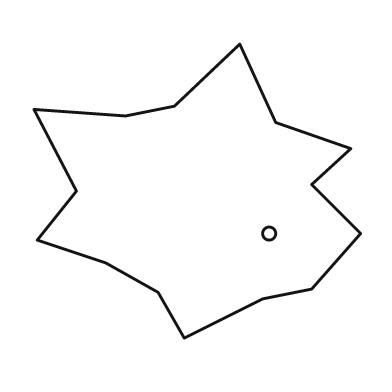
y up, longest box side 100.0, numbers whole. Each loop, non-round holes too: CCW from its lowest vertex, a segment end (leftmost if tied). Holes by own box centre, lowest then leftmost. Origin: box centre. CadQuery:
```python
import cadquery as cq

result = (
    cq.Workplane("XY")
    .moveTo(-4.0, -45.0)
    .lineTo(20.0, -33.0)
    .lineTo(35.0, -30.0)
    .lineTo(50.0, -13.0)
    .lineTo(35.0, 2.0)
    .lineTo(47.0, 13.0)
    .lineTo(24.0, 21.0)
    .lineTo(13.0, 45.0)
    .lineTo(-7.0, 26.0)
    .lineTo(-22.0, 23.0)
    .lineTo(-50.0, 25.0)
    .lineTo(-37.0, 0.0)
    .lineTo(-49.0, -15.0)
    .lineTo(-28.0, -22.0)
    .lineTo(-12.0, -31.0)
    .close()
    .moveTo(22.0, -13.0)
    .circle(2.0)
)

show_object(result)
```